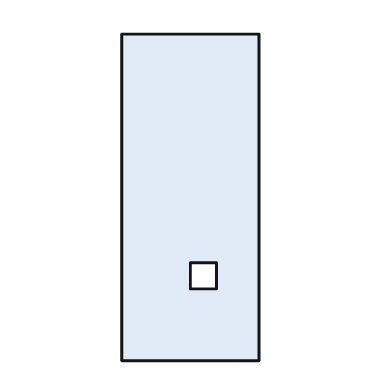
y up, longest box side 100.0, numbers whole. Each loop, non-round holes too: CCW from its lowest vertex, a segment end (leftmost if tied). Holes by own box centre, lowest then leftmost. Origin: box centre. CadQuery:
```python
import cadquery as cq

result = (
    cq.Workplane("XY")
    .moveTo(-21.0, -50.0)
    .lineTo(21.0, -50.0)
    .lineTo(21.0, 50.0)
    .lineTo(-21.0, 50.0)
    .close()
    .moveTo(0.0, -28.0)
    .lineTo(8.0, -28.0)
    .lineTo(8.0, -20.0)
    .lineTo(0.0, -20.0)
    .close()
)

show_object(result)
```